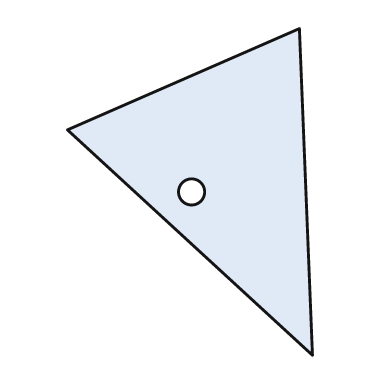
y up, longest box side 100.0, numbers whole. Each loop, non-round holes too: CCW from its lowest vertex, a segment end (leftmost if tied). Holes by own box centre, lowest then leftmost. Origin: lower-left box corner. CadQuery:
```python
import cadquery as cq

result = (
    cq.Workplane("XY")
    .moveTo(75.0, 0.0)
    .lineTo(71.0, 100.0)
    .lineTo(0.0, 69.0)
    .close()
    .moveTo(38.0, 50.0)
    .circle(4.0)
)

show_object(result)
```